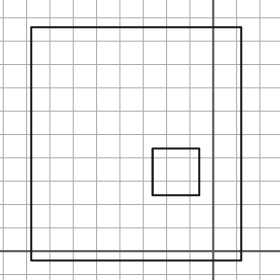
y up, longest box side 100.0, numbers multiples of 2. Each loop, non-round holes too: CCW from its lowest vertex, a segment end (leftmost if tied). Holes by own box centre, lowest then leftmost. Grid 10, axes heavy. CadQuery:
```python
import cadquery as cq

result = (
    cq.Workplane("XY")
    .moveTo(-78.0, -4.0)
    .lineTo(12.0, -4.0)
    .lineTo(12.0, 96.0)
    .lineTo(-78.0, 96.0)
    .close()
    .moveTo(-26.0, 24.0)
    .lineTo(-6.0, 24.0)
    .lineTo(-6.0, 44.0)
    .lineTo(-26.0, 44.0)
    .close()
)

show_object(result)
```